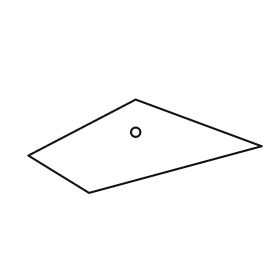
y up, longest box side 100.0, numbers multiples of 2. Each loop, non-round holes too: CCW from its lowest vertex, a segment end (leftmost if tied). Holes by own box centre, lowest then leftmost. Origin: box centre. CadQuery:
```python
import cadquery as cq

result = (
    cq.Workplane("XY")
    .moveTo(-24.0, -20.0)
    .lineTo(50.0, 0.0)
    .lineTo(-4.0, 20.0)
    .lineTo(-50.0, -4.0)
    .close()
    .moveTo(-4.0, 6.0)
    .circle(2.0)
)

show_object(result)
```